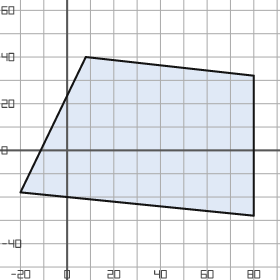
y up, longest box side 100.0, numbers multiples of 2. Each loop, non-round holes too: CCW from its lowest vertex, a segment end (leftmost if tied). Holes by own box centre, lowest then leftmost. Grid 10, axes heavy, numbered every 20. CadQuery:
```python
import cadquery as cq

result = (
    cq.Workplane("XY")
    .moveTo(80.0, -28.0)
    .lineTo(80.0, 32.0)
    .lineTo(8.0, 40.0)
    .lineTo(-20.0, -18.0)
    .close()
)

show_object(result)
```